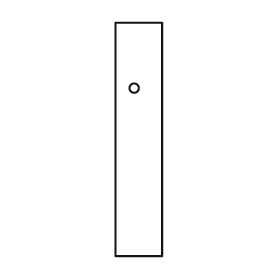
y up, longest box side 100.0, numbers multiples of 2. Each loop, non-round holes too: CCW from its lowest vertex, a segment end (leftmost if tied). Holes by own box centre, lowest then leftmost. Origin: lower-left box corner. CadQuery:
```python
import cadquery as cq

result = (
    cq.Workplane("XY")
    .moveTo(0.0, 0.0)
    .lineTo(20.0, 0.0)
    .lineTo(20.0, 100.0)
    .lineTo(0.0, 100.0)
    .close()
    .moveTo(8.0, 72.0)
    .circle(2.0)
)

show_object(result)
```